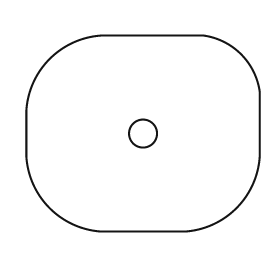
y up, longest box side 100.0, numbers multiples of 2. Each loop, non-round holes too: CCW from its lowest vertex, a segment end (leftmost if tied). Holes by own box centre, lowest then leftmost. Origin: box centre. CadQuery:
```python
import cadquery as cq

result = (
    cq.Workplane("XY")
    .moveTo(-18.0, -42.0)
    .lineTo(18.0, -42.0)
    .threePointArc((40.0, -32.0), (50.0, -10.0))
    .lineTo(50.0, 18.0)
    .threePointArc((42.0, 34.0), (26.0, 42.0))
    .lineTo(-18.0, 42.0)
    .threePointArc((-40.0, 32.0), (-50.0, 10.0))
    .lineTo(-50.0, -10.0)
    .threePointArc((-40.0, -32.0), (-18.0, -42.0))
    .close()
    .moveTo(0.0, 0.0)
    .circle(6.0)
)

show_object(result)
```